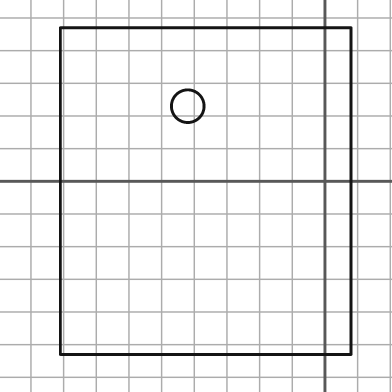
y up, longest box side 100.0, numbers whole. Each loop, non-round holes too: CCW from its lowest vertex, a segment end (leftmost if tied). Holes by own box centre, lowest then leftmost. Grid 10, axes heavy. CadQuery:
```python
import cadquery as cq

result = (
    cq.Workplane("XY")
    .moveTo(-81.0, -53.0)
    .lineTo(8.0, -53.0)
    .lineTo(8.0, 47.0)
    .lineTo(-81.0, 47.0)
    .close()
    .moveTo(-42.0, 23.0)
    .circle(5.0)
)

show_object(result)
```